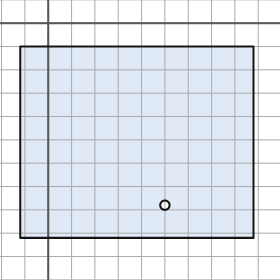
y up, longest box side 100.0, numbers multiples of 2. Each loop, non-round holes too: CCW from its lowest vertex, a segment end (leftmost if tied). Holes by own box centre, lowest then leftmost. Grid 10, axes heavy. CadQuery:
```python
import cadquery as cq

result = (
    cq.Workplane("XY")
    .moveTo(-12.0, -92.0)
    .lineTo(88.0, -92.0)
    .lineTo(88.0, -10.0)
    .lineTo(-12.0, -10.0)
    .close()
    .moveTo(50.0, -78.0)
    .circle(2.0)
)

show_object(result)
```